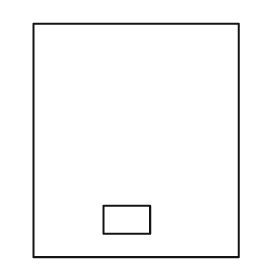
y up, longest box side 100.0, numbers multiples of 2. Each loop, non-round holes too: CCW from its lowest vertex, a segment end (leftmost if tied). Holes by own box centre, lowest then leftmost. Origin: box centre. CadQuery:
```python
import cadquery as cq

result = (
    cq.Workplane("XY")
    .moveTo(-44.0, -50.0)
    .lineTo(44.0, -50.0)
    .lineTo(44.0, 50.0)
    .lineTo(-44.0, 50.0)
    .close()
    .moveTo(-14.0, -40.0)
    .lineTo(6.0, -40.0)
    .lineTo(6.0, -28.0)
    .lineTo(-14.0, -28.0)
    .close()
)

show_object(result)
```